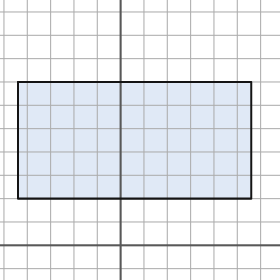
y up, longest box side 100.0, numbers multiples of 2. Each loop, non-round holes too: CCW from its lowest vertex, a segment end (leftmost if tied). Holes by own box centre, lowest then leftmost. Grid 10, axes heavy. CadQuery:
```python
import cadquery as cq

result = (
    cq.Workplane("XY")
    .moveTo(-44.0, 20.0)
    .lineTo(56.0, 20.0)
    .lineTo(56.0, 70.0)
    .lineTo(-44.0, 70.0)
    .close()
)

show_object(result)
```